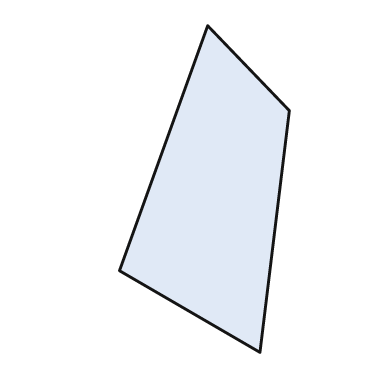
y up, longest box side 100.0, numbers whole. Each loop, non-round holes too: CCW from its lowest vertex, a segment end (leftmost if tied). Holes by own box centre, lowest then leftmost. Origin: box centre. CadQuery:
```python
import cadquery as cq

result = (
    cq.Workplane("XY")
    .moveTo(17.0, -50.0)
    .lineTo(26.0, 24.0)
    .lineTo(1.0, 50.0)
    .lineTo(-26.0, -25.0)
    .close()
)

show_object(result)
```